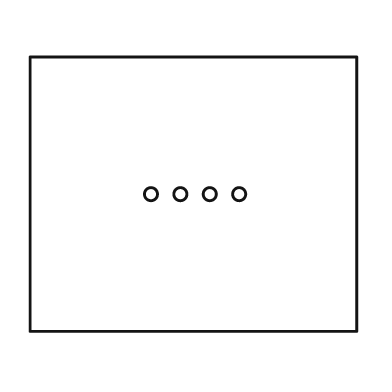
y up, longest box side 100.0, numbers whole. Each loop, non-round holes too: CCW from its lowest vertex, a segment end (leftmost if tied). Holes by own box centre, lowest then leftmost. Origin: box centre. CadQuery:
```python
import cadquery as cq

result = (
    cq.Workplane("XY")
    .moveTo(-50.0, -42.0)
    .lineTo(50.0, -42.0)
    .lineTo(50.0, 42.0)
    .lineTo(-50.0, 42.0)
    .close()
    .moveTo(-13.0, 0.0)
    .circle(2.0)
    .moveTo(-4.0, 0.0)
    .circle(2.0)
    .moveTo(5.0, 0.0)
    .circle(2.0)
    .moveTo(14.0, 0.0)
    .circle(2.0)
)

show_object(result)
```